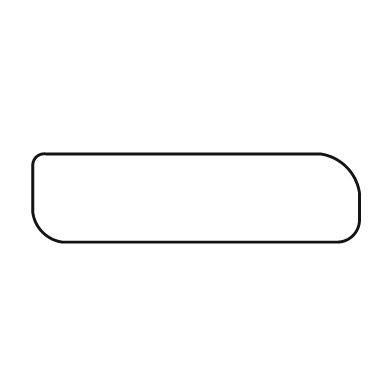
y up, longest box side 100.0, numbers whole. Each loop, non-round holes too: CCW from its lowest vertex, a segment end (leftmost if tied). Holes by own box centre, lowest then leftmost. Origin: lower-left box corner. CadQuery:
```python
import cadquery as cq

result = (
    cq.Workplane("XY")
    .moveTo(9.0, 0.0)
    .lineTo(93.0, 0.0)
    .threePointArc((98.0, 2.0), (100.0, 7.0))
    .lineTo(100.0, 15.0)
    .threePointArc((96.0, 23.0), (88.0, 27.0))
    .lineTo(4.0, 27.0)
    .threePointArc((1.0, 26.0), (0.0, 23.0))
    .lineTo(0.0, 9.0)
    .threePointArc((3.0, 3.0), (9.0, 0.0))
    .close()
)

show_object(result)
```